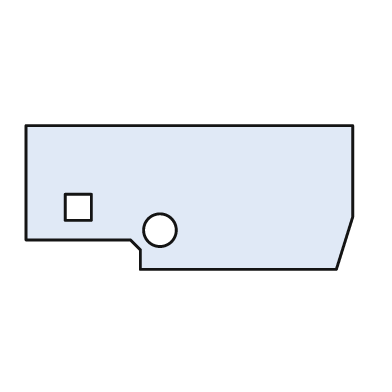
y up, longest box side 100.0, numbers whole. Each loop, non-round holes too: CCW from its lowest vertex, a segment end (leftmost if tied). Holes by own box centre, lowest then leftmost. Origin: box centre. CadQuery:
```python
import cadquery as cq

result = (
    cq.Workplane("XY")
    .moveTo(-15.0, -22.0)
    .lineTo(45.0, -22.0)
    .lineTo(50.0, -6.0)
    .lineTo(50.0, 22.0)
    .lineTo(-50.0, 22.0)
    .lineTo(-50.0, -13.0)
    .lineTo(-18.0, -13.0)
    .lineTo(-15.0, -16.0)
    .close()
    .moveTo(-9.0, -10.0)
    .circle(5.0)
    .moveTo(-38.0, -7.0)
    .lineTo(-30.0, -7.0)
    .lineTo(-30.0, 1.0)
    .lineTo(-38.0, 1.0)
    .close()
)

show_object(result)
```